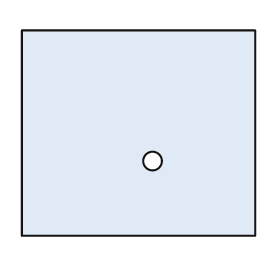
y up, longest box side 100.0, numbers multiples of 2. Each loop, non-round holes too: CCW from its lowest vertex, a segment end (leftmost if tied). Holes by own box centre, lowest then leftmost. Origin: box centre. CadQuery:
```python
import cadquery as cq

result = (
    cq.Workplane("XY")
    .moveTo(-50.0, -44.0)
    .lineTo(50.0, -44.0)
    .lineTo(50.0, 44.0)
    .lineTo(-50.0, 44.0)
    .close()
    .moveTo(6.0, -12.0)
    .circle(4.0)
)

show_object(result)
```